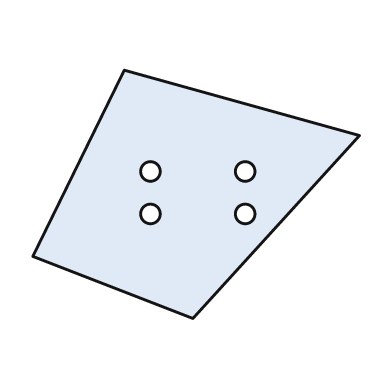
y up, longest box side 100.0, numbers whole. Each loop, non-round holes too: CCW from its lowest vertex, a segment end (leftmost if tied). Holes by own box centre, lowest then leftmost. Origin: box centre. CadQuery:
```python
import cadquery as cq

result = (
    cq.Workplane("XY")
    .moveTo(-1.0, -38.0)
    .lineTo(50.0, 18.0)
    .lineTo(-22.0, 38.0)
    .lineTo(-50.0, -19.0)
    .close()
    .moveTo(-14.0, -6.0)
    .circle(3.0)
    .moveTo(15.0, -6.0)
    .circle(3.0)
    .moveTo(-14.0, 7.0)
    .circle(3.0)
    .moveTo(15.0, 7.0)
    .circle(3.0)
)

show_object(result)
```